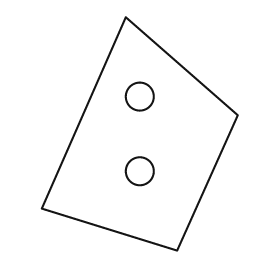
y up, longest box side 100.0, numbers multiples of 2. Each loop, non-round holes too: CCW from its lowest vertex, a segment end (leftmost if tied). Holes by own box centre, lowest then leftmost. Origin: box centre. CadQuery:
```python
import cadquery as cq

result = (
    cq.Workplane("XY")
    .moveTo(16.0, -50.0)
    .lineTo(42.0, 8.0)
    .lineTo(-6.0, 50.0)
    .lineTo(-42.0, -32.0)
    .close()
    .moveTo(0.0, -16.0)
    .circle(6.0)
    .moveTo(0.0, 16.0)
    .circle(6.0)
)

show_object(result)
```